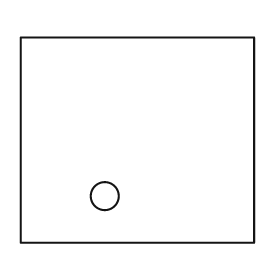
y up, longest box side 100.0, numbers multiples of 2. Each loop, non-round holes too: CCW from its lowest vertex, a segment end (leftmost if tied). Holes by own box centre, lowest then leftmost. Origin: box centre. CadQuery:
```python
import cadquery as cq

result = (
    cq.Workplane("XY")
    .moveTo(-50.0, -44.0)
    .lineTo(50.0, -44.0)
    .lineTo(50.0, 44.0)
    .lineTo(-50.0, 44.0)
    .close()
    .moveTo(-14.0, -24.0)
    .circle(6.0)
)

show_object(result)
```